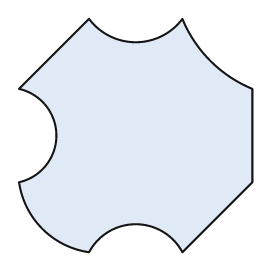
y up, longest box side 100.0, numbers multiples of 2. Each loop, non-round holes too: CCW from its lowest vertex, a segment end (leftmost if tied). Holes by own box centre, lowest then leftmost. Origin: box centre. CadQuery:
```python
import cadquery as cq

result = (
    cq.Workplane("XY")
    .moveTo(-20.0, -50.0)
    .threePointArc((0.0, -38.0), (20.0, -50.0))
    .lineTo(50.0, -20.0)
    .lineTo(50.0, 20.0)
    .threePointArc((32.0, 32.0), (20.0, 50.0))
    .threePointArc((0.0, 40.0), (-20.0, 50.0))
    .lineTo(-50.0, 20.0)
    .threePointArc((-34.0, 0.0), (-50.0, -20.0))
    .threePointArc((-40.0, -40.0), (-20.0, -50.0))
    .close()
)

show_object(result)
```